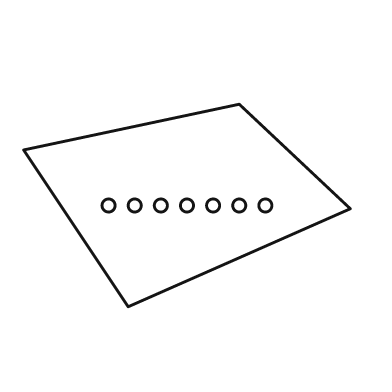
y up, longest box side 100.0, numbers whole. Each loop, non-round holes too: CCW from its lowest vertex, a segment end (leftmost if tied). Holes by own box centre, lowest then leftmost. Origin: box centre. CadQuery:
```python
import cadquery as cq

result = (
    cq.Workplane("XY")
    .moveTo(-18.0, -31.0)
    .lineTo(50.0, -1.0)
    .lineTo(16.0, 31.0)
    .lineTo(-50.0, 17.0)
    .close()
    .moveTo(-24.0, 0.0)
    .circle(2.0)
    .moveTo(-16.0, 0.0)
    .circle(2.0)
    .moveTo(-8.0, 0.0)
    .circle(2.0)
    .moveTo(0.0, 0.0)
    .circle(2.0)
    .moveTo(8.0, 0.0)
    .circle(2.0)
    .moveTo(16.0, 0.0)
    .circle(2.0)
    .moveTo(24.0, 0.0)
    .circle(2.0)
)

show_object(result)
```